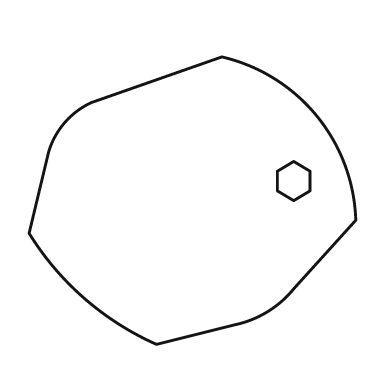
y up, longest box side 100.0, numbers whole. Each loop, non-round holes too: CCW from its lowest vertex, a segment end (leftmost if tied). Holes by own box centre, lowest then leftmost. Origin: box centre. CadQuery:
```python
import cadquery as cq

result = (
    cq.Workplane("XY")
    .moveTo(-11.0, -44.0)
    .lineTo(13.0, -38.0)
    .threePointArc((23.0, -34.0), (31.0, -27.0))
    .lineTo(50.0, -6.0)
    .threePointArc((38.0, 26.0), (9.0, 44.0))
    .lineTo(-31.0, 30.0)
    .threePointArc((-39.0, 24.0), (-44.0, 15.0))
    .lineTo(-50.0, -10.0)
    .threePointArc((-33.0, -30.0), (-11.0, -44.0))
    .close()
    .moveTo(31.0, 0.0)
    .lineTo(36.0, 3.0)
    .lineTo(36.0, 9.0)
    .lineTo(31.0, 12.0)
    .lineTo(26.0, 9.0)
    .lineTo(26.0, 3.0)
    .close()
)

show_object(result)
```